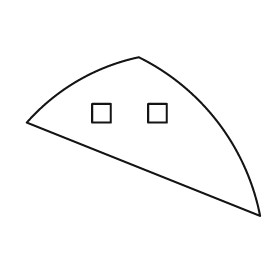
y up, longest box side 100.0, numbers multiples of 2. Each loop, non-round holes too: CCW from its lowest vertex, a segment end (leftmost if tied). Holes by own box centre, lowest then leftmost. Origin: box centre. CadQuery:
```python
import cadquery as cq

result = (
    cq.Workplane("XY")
    .moveTo(50.0, -34.0)
    .threePointArc((32.0, 6.0), (-2.0, 34.0))
    .threePointArc((-28.0, 24.0), (-50.0, 6.0))
    .close()
    .moveTo(-22.0, 6.0)
    .lineTo(-14.0, 6.0)
    .lineTo(-14.0, 14.0)
    .lineTo(-22.0, 14.0)
    .close()
    .moveTo(2.0, 6.0)
    .lineTo(10.0, 6.0)
    .lineTo(10.0, 14.0)
    .lineTo(2.0, 14.0)
    .close()
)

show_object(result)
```